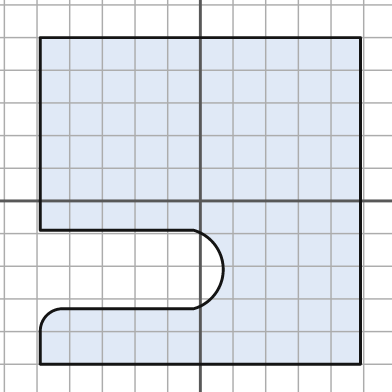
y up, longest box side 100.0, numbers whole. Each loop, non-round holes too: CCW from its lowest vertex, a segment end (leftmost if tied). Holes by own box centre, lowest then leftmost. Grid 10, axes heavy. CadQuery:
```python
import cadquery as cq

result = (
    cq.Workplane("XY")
    .moveTo(-49.0, -50.0)
    .lineTo(49.0, -50.0)
    .lineTo(49.0, 50.0)
    .lineTo(-49.0, 50.0)
    .lineTo(-49.0, -9.0)
    .lineTo(-2.0, -9.0)
    .threePointArc((7.0, -21.0), (-2.0, -33.0))
    .lineTo(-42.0, -33.0)
    .threePointArc((-47.0, -35.0), (-49.0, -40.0))
    .close()
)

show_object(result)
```